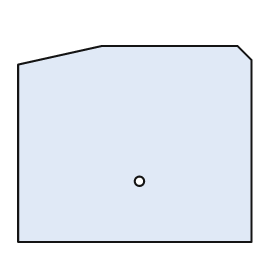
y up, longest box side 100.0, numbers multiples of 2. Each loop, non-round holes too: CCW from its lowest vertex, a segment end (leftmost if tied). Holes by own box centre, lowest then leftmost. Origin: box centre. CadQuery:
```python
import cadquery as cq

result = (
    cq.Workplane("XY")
    .moveTo(-50.0, -42.0)
    .lineTo(50.0, -42.0)
    .lineTo(50.0, 36.0)
    .lineTo(44.0, 42.0)
    .lineTo(-14.0, 42.0)
    .lineTo(-50.0, 34.0)
    .close()
    .moveTo(2.0, -16.0)
    .circle(2.0)
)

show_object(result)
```